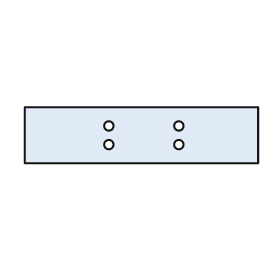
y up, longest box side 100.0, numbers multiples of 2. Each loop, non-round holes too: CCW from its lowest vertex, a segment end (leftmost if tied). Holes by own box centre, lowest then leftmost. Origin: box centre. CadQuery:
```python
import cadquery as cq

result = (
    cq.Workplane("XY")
    .moveTo(-50.0, -12.0)
    .lineTo(50.0, -12.0)
    .lineTo(50.0, 12.0)
    .lineTo(-50.0, 12.0)
    .close()
    .moveTo(-14.0, -4.0)
    .circle(2.0)
    .moveTo(16.0, -4.0)
    .circle(2.0)
    .moveTo(-14.0, 4.0)
    .circle(2.0)
    .moveTo(16.0, 4.0)
    .circle(2.0)
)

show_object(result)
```